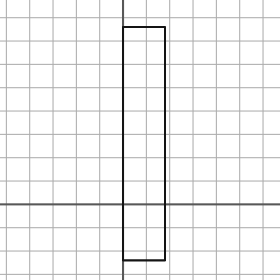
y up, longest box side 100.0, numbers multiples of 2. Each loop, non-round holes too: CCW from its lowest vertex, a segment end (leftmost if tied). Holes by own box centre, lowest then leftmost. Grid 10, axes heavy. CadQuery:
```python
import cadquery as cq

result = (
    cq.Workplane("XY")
    .moveTo(0.0, -24.0)
    .lineTo(18.0, -24.0)
    .lineTo(18.0, 76.0)
    .lineTo(0.0, 76.0)
    .close()
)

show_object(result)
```